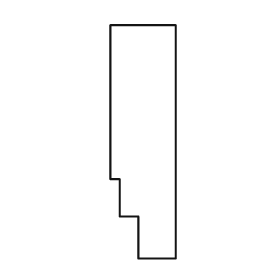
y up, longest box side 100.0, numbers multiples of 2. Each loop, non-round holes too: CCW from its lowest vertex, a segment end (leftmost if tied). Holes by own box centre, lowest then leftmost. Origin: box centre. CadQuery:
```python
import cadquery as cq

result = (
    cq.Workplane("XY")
    .moveTo(-2.0, -50.0)
    .lineTo(14.0, -50.0)
    .lineTo(14.0, 50.0)
    .lineTo(-14.0, 50.0)
    .lineTo(-14.0, -16.0)
    .lineTo(-10.0, -16.0)
    .lineTo(-10.0, -32.0)
    .lineTo(-2.0, -32.0)
    .close()
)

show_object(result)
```